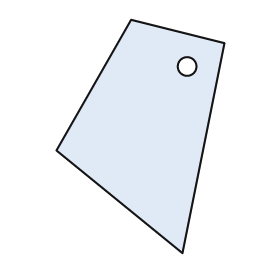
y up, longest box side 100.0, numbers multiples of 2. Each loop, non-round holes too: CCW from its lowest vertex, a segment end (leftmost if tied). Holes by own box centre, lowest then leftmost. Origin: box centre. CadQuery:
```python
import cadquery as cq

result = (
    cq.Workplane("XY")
    .moveTo(18.0, -50.0)
    .lineTo(36.0, 40.0)
    .lineTo(-4.0, 50.0)
    .lineTo(-36.0, -6.0)
    .close()
    .moveTo(20.0, 30.0)
    .circle(4.0)
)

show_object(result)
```